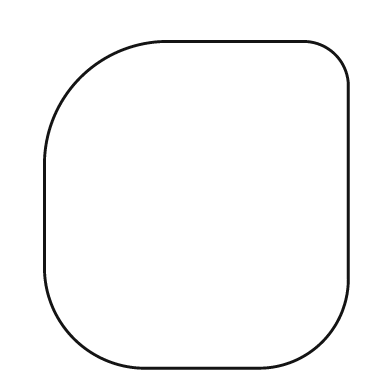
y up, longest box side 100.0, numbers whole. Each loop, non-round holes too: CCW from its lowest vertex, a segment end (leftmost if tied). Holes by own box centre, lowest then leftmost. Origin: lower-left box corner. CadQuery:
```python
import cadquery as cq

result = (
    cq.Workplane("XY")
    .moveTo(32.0, 0.0)
    .lineTo(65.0, 0.0)
    .threePointArc((85.0, 8.0), (93.0, 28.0))
    .lineTo(93.0, 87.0)
    .threePointArc((89.0, 96.0), (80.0, 100.0))
    .lineTo(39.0, 100.0)
    .threePointArc((11.0, 89.0), (0.0, 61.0))
    .lineTo(0.0, 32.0)
    .threePointArc((9.0, 9.0), (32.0, 0.0))
    .close()
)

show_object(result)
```